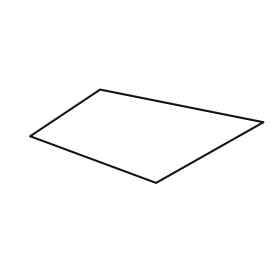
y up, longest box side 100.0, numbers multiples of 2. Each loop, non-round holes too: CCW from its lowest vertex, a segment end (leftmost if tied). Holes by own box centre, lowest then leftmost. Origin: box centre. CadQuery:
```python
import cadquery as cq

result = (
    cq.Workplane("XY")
    .moveTo(4.0, -20.0)
    .lineTo(50.0, 6.0)
    .lineTo(-20.0, 20.0)
    .lineTo(-50.0, 0.0)
    .close()
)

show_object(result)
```